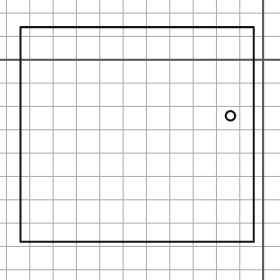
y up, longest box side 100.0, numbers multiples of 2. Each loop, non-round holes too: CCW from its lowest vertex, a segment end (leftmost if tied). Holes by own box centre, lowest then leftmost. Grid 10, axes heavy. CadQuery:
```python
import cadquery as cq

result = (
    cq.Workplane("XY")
    .moveTo(-104.0, -78.0)
    .lineTo(-4.0, -78.0)
    .lineTo(-4.0, 14.0)
    .lineTo(-104.0, 14.0)
    .close()
    .moveTo(-14.0, -24.0)
    .circle(2.0)
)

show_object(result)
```